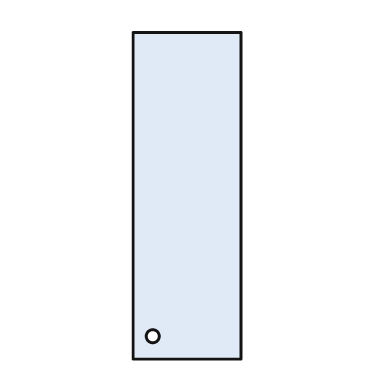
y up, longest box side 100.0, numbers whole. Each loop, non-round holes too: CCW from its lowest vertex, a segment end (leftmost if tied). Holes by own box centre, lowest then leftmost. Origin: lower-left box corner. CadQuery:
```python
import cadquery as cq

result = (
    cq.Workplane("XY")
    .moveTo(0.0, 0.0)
    .lineTo(33.0, 0.0)
    .lineTo(33.0, 100.0)
    .lineTo(0.0, 100.0)
    .close()
    .moveTo(6.0, 7.0)
    .circle(2.0)
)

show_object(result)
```